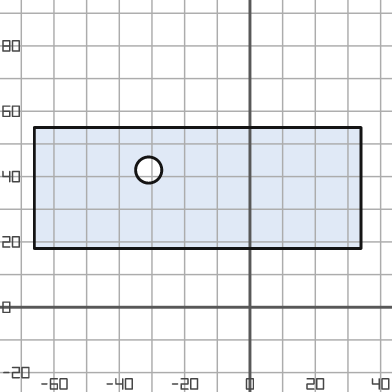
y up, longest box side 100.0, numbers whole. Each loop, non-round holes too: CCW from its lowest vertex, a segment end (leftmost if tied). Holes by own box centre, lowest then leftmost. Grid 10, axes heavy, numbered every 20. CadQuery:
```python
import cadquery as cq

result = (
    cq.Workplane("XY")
    .moveTo(-66.0, 18.0)
    .lineTo(34.0, 18.0)
    .lineTo(34.0, 55.0)
    .lineTo(-66.0, 55.0)
    .close()
    .moveTo(-31.0, 42.0)
    .circle(4.0)
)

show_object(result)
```